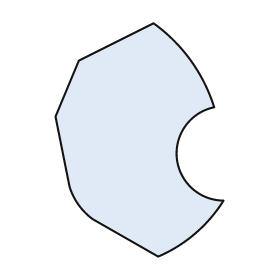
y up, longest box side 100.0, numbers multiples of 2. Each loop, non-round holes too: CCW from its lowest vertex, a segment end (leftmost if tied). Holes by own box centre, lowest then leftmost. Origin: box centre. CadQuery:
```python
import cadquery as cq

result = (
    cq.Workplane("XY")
    .moveTo(8.0, -50.0)
    .threePointArc((24.0, -40.0), (36.0, -26.0))
    .threePointArc((16.0, -8.0), (32.0, 14.0))
    .threePointArc((22.0, 34.0), (6.0, 50.0))
    .lineTo(-26.0, 34.0)
    .lineTo(-36.0, 10.0)
    .lineTo(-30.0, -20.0)
    .threePointArc((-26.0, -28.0), (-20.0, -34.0))
    .close()
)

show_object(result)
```